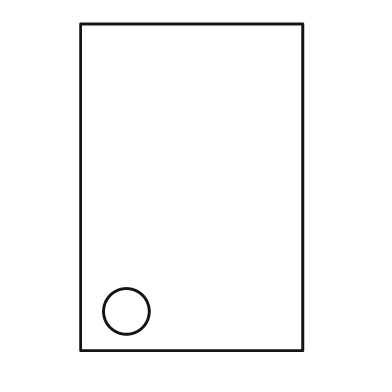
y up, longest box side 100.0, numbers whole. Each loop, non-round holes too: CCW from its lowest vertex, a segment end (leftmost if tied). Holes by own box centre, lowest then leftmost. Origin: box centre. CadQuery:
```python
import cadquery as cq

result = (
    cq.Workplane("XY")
    .moveTo(-34.0, -50.0)
    .lineTo(34.0, -50.0)
    .lineTo(34.0, 50.0)
    .lineTo(-34.0, 50.0)
    .close()
    .moveTo(-20.0, -38.0)
    .circle(7.0)
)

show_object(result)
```